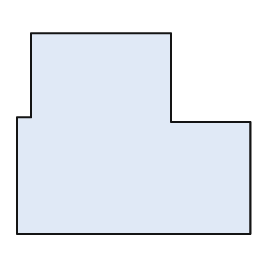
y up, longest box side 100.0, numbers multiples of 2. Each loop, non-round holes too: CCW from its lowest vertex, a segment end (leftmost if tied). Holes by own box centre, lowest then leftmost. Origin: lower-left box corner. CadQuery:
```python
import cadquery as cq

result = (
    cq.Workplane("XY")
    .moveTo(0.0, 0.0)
    .lineTo(100.0, 0.0)
    .lineTo(100.0, 48.0)
    .lineTo(66.0, 48.0)
    .lineTo(66.0, 86.0)
    .lineTo(6.0, 86.0)
    .lineTo(6.0, 50.0)
    .lineTo(0.0, 50.0)
    .close()
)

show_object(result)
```